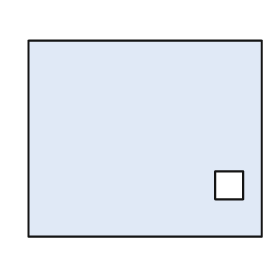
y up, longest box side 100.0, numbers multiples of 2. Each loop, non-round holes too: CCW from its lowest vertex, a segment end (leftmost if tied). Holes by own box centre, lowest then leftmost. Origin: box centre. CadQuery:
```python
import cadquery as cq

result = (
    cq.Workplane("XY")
    .moveTo(-50.0, -42.0)
    .lineTo(50.0, -42.0)
    .lineTo(50.0, 42.0)
    .lineTo(-50.0, 42.0)
    .close()
    .moveTo(30.0, -26.0)
    .lineTo(42.0, -26.0)
    .lineTo(42.0, -14.0)
    .lineTo(30.0, -14.0)
    .close()
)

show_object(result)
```